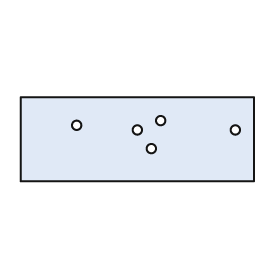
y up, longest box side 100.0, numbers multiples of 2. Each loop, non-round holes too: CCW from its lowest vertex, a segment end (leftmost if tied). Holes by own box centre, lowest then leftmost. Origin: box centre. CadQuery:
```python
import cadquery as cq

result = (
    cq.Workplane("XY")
    .moveTo(-50.0, -18.0)
    .lineTo(50.0, -18.0)
    .lineTo(50.0, 18.0)
    .lineTo(-50.0, 18.0)
    .close()
    .moveTo(6.0, -4.0)
    .circle(2.0)
    .moveTo(0.0, 4.0)
    .circle(2.0)
    .moveTo(42.0, 4.0)
    .circle(2.0)
    .moveTo(-26.0, 6.0)
    .circle(2.0)
    .moveTo(10.0, 8.0)
    .circle(2.0)
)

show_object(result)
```